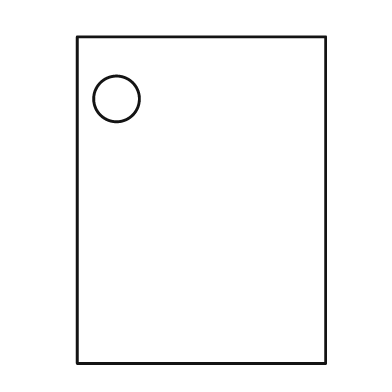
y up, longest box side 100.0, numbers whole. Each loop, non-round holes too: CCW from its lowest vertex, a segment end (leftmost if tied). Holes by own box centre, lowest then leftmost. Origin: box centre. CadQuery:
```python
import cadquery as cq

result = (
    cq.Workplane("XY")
    .moveTo(-38.0, -50.0)
    .lineTo(38.0, -50.0)
    .lineTo(38.0, 50.0)
    .lineTo(-38.0, 50.0)
    .close()
    .moveTo(-26.0, 31.0)
    .circle(7.0)
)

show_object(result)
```